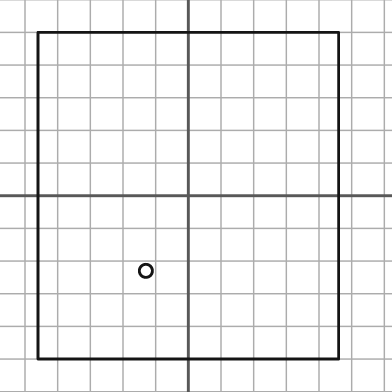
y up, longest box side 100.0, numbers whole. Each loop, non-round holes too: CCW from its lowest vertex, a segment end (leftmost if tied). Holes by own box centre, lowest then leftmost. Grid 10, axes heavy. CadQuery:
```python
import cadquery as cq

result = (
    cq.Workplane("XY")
    .moveTo(-46.0, -50.0)
    .lineTo(46.0, -50.0)
    .lineTo(46.0, 50.0)
    .lineTo(-46.0, 50.0)
    .close()
    .moveTo(-13.0, -23.0)
    .circle(2.0)
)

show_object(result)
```